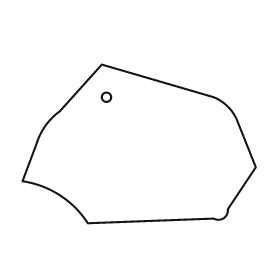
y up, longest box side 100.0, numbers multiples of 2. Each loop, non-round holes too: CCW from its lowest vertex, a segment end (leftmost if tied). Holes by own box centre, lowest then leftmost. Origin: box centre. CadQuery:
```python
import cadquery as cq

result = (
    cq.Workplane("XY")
    .moveTo(-22.0, -34.0)
    .lineTo(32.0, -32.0)
    .threePointArc((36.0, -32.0), (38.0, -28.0))
    .lineTo(50.0, -10.0)
    .lineTo(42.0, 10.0)
    .threePointArc((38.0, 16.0), (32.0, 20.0))
    .lineTo(-16.0, 34.0)
    .lineTo(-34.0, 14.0)
    .threePointArc((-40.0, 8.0), (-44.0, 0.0))
    .lineTo(-50.0, -16.0)
    .threePointArc((-34.0, -22.0), (-22.0, -34.0))
    .close()
    .moveTo(-14.0, 20.0)
    .circle(2.0)
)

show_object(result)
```